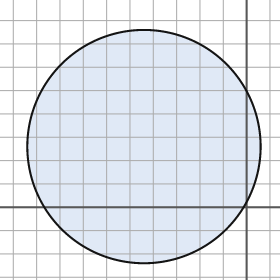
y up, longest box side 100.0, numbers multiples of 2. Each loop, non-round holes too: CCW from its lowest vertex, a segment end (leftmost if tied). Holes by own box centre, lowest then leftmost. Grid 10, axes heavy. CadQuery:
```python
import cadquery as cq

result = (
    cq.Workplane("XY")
    .moveTo(-44.0, 26.0)
    .circle(50.0)
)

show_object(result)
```